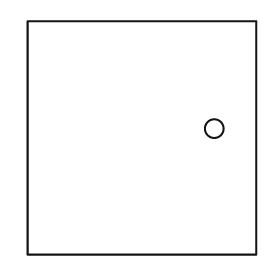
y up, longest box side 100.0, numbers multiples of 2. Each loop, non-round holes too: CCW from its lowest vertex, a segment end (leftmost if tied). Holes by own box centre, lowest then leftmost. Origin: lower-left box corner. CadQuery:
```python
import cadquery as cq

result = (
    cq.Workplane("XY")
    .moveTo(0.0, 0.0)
    .lineTo(98.0, 0.0)
    .lineTo(98.0, 100.0)
    .lineTo(0.0, 100.0)
    .close()
    .moveTo(80.0, 54.0)
    .circle(4.0)
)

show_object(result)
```